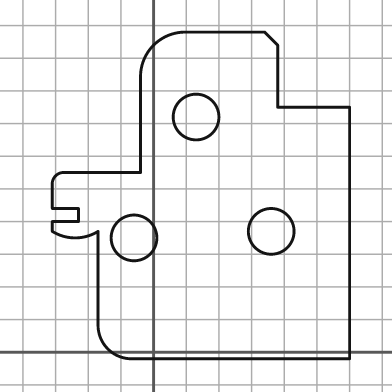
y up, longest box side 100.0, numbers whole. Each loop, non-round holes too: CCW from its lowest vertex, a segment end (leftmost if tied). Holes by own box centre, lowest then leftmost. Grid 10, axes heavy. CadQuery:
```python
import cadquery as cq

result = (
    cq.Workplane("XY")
    .moveTo(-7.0, -2.0)
    .lineTo(60.0, -2.0)
    .lineTo(60.0, 75.0)
    .lineTo(38.0, 75.0)
    .lineTo(38.0, 94.0)
    .lineTo(34.0, 98.0)
    .lineTo(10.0, 98.0)
    .threePointArc((0.0, 94.0), (-4.0, 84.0))
    .lineTo(-4.0, 55.0)
    .lineTo(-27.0, 55.0)
    .threePointArc((-30.0, 54.0), (-31.0, 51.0))
    .lineTo(-31.0, 44.0)
    .lineTo(-23.0, 44.0)
    .lineTo(-23.0, 40.0)
    .lineTo(-31.0, 40.0)
    .lineTo(-31.0, 37.0)
    .threePointArc((-24.0, 35.0), (-17.0, 37.0))
    .lineTo(-17.0, 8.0)
    .threePointArc((-14.0, 1.0), (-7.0, -2.0))
    .close()
    .moveTo(-6.0, 35.0)
    .circle(7.0)
    .moveTo(36.0, 37.0)
    .circle(7.0)
    .moveTo(13.0, 72.0)
    .circle(7.0)
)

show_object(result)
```